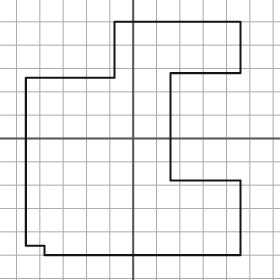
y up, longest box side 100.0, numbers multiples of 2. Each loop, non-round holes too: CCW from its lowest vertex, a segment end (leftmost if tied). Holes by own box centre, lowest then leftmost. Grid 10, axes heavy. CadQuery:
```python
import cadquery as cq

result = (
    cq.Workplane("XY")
    .moveTo(-38.0, -50.0)
    .lineTo(46.0, -50.0)
    .lineTo(46.0, -18.0)
    .lineTo(16.0, -18.0)
    .lineTo(16.0, 28.0)
    .lineTo(46.0, 28.0)
    .lineTo(46.0, 50.0)
    .lineTo(-8.0, 50.0)
    .lineTo(-8.0, 26.0)
    .lineTo(-46.0, 26.0)
    .lineTo(-46.0, -46.0)
    .lineTo(-38.0, -46.0)
    .close()
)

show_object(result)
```